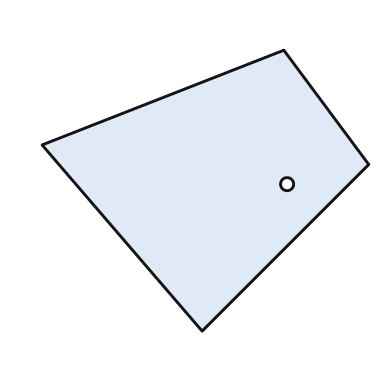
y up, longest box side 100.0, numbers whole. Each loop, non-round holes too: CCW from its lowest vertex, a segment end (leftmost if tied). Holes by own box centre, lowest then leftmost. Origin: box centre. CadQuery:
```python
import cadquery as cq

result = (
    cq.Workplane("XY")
    .moveTo(-1.0, -43.0)
    .lineTo(50.0, 8.0)
    .lineTo(24.0, 43.0)
    .lineTo(-50.0, 14.0)
    .close()
    .moveTo(25.0, 2.0)
    .circle(2.0)
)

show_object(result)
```